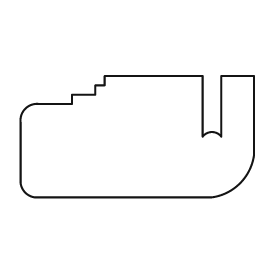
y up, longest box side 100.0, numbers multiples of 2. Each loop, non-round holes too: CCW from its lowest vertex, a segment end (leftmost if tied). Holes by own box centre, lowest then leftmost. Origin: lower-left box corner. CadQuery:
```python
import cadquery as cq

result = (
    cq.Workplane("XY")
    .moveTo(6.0, 0.0)
    .lineTo(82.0, 0.0)
    .threePointArc((94.0, 6.0), (100.0, 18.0))
    .lineTo(100.0, 52.0)
    .lineTo(86.0, 52.0)
    .lineTo(86.0, 26.0)
    .threePointArc((82.0, 28.0), (78.0, 26.0))
    .lineTo(78.0, 52.0)
    .lineTo(36.0, 52.0)
    .lineTo(36.0, 48.0)
    .lineTo(32.0, 48.0)
    .lineTo(32.0, 44.0)
    .lineTo(22.0, 44.0)
    .lineTo(22.0, 40.0)
    .lineTo(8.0, 40.0)
    .threePointArc((2.0, 38.0), (0.0, 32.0))
    .lineTo(0.0, 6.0)
    .threePointArc((2.0, 2.0), (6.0, 0.0))
    .close()
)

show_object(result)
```